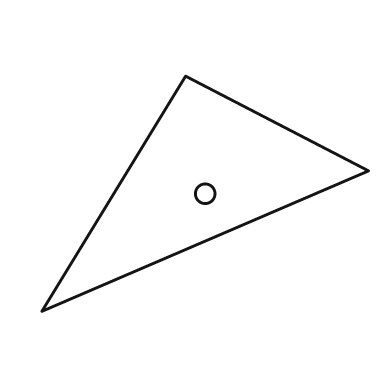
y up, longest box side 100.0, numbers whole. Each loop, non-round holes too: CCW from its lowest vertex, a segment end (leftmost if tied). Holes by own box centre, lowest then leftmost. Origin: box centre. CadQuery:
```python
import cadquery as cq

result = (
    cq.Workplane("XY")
    .moveTo(-50.0, -36.0)
    .lineTo(50.0, 7.0)
    .lineTo(-6.0, 36.0)
    .close()
    .moveTo(0.0, 0.0)
    .circle(3.0)
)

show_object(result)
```